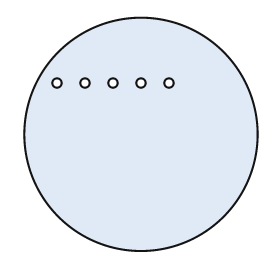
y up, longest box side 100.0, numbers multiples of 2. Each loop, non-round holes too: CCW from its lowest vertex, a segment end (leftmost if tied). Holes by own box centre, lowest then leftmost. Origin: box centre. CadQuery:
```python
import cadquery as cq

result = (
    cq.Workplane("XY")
    .moveTo(0.0, 0.0)
    .circle(50.0)
    .moveTo(-36.0, 22.0)
    .circle(2.0)
    .moveTo(-24.0, 22.0)
    .circle(2.0)
    .moveTo(-12.0, 22.0)
    .circle(2.0)
    .moveTo(0.0, 22.0)
    .circle(2.0)
    .moveTo(12.0, 22.0)
    .circle(2.0)
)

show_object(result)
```